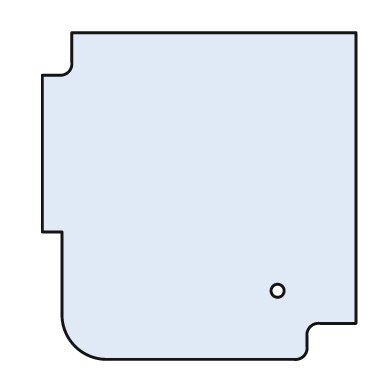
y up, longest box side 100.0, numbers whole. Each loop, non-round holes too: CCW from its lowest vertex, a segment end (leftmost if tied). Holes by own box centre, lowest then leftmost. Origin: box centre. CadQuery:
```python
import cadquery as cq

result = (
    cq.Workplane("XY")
    .moveTo(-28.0, -50.0)
    .lineTo(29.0, -50.0)
    .threePointArc((32.0, -49.0), (33.0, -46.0))
    .lineTo(33.0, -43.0)
    .threePointArc((34.0, -40.0), (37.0, -39.0))
    .lineTo(48.0, -39.0)
    .lineTo(48.0, 50.0)
    .lineTo(-39.0, 50.0)
    .lineTo(-39.0, 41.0)
    .threePointArc((-40.0, 38.0), (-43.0, 37.0))
    .lineTo(-48.0, 37.0)
    .lineTo(-48.0, -11.0)
    .lineTo(-42.0, -11.0)
    .lineTo(-42.0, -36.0)
    .threePointArc((-38.0, -46.0), (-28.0, -50.0))
    .close()
    .moveTo(24.0, -29.0)
    .circle(2.0)
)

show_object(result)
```